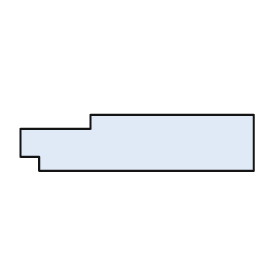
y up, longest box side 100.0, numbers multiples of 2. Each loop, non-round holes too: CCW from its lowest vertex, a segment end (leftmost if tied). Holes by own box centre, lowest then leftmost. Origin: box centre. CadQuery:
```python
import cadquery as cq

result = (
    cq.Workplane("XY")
    .moveTo(-42.0, -12.0)
    .lineTo(50.0, -12.0)
    .lineTo(50.0, 12.0)
    .lineTo(-20.0, 12.0)
    .lineTo(-20.0, 6.0)
    .lineTo(-50.0, 6.0)
    .lineTo(-50.0, -6.0)
    .lineTo(-42.0, -6.0)
    .close()
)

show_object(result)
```